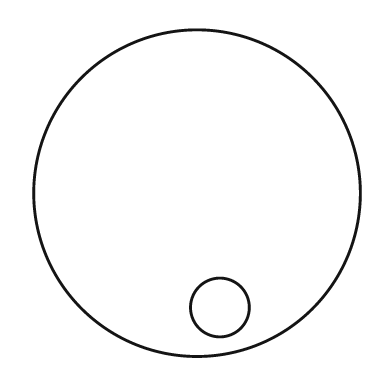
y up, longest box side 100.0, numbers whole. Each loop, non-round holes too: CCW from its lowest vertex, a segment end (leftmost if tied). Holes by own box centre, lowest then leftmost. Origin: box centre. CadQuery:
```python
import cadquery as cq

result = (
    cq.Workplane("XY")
    .moveTo(0.0, 0.0)
    .circle(50.0)
    .moveTo(7.0, -35.0)
    .circle(9.0)
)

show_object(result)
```